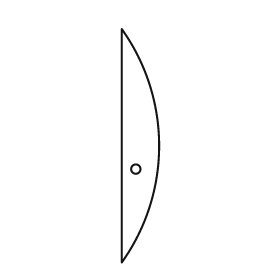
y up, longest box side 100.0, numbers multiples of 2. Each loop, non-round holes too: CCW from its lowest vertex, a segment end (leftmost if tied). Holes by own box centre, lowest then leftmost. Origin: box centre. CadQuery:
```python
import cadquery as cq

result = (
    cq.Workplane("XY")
    .moveTo(-8.0, -50.0)
    .threePointArc((8.0, 0.0), (-8.0, 50.0))
    .close()
    .moveTo(-2.0, -10.0)
    .circle(2.0)
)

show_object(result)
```